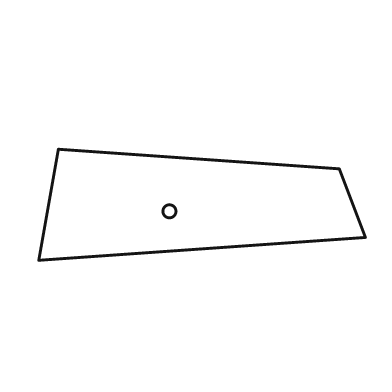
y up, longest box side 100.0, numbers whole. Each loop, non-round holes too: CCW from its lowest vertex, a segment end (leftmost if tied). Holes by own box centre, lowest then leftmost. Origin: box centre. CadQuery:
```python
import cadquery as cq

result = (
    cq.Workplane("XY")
    .moveTo(-50.0, -17.0)
    .lineTo(50.0, -10.0)
    .lineTo(42.0, 11.0)
    .lineTo(-44.0, 17.0)
    .close()
    .moveTo(-10.0, -2.0)
    .circle(2.0)
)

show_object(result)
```